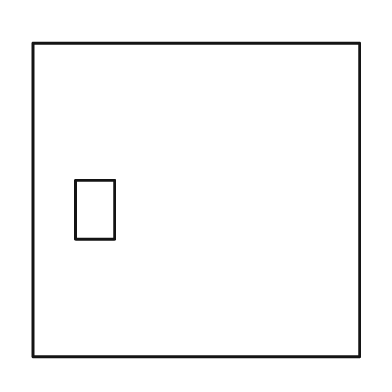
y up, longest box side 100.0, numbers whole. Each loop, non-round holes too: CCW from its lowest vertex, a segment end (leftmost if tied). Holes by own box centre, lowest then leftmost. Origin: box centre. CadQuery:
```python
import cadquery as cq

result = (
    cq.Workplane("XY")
    .moveTo(-50.0, -48.0)
    .lineTo(50.0, -48.0)
    .lineTo(50.0, 48.0)
    .lineTo(-50.0, 48.0)
    .close()
    .moveTo(-37.0, -12.0)
    .lineTo(-25.0, -12.0)
    .lineTo(-25.0, 6.0)
    .lineTo(-37.0, 6.0)
    .close()
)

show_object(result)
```